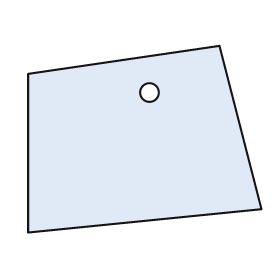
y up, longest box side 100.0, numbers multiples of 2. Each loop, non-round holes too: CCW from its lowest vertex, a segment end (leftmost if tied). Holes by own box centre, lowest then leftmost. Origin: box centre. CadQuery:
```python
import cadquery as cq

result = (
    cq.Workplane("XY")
    .moveTo(-50.0, -40.0)
    .lineTo(50.0, -30.0)
    .lineTo(32.0, 40.0)
    .lineTo(-50.0, 28.0)
    .close()
    .moveTo(2.0, 20.0)
    .circle(4.0)
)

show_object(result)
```